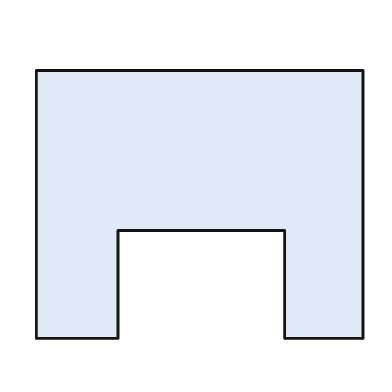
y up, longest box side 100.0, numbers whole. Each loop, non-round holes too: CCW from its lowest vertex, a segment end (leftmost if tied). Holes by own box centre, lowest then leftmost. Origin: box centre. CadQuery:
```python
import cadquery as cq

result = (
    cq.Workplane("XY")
    .moveTo(-50.0, -41.0)
    .lineTo(-25.0, -41.0)
    .lineTo(-25.0, -8.0)
    .lineTo(26.0, -8.0)
    .lineTo(26.0, -41.0)
    .lineTo(50.0, -41.0)
    .lineTo(50.0, 41.0)
    .lineTo(-50.0, 41.0)
    .close()
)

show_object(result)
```